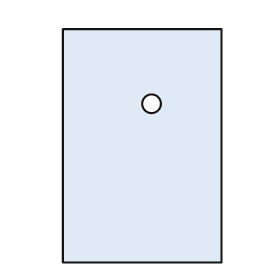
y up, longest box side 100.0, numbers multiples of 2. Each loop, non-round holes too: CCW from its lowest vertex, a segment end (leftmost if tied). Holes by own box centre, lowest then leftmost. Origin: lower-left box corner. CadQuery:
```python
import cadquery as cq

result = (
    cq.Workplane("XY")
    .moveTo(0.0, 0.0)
    .lineTo(68.0, 0.0)
    .lineTo(68.0, 100.0)
    .lineTo(0.0, 100.0)
    .close()
    .moveTo(38.0, 68.0)
    .circle(4.0)
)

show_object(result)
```